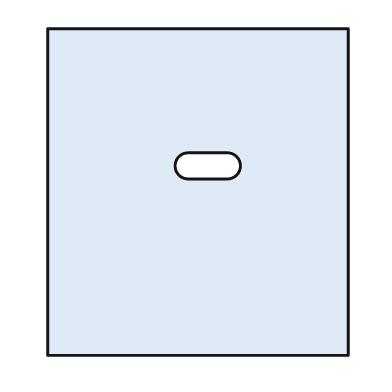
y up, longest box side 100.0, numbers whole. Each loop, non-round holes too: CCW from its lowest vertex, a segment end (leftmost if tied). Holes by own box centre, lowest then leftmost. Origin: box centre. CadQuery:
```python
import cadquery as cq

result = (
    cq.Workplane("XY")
    .moveTo(-46.0, -50.0)
    .lineTo(46.0, -50.0)
    .lineTo(46.0, 50.0)
    .lineTo(-46.0, 50.0)
    .close()
    .moveTo(-3.0, 4.0)
    .lineTo(9.0, 4.0)
    .threePointArc((13.0, 8.0), (9.0, 12.0))
    .lineTo(-3.0, 12.0)
    .threePointArc((-7.0, 8.0), (-3.0, 4.0))
    .close()
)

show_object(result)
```